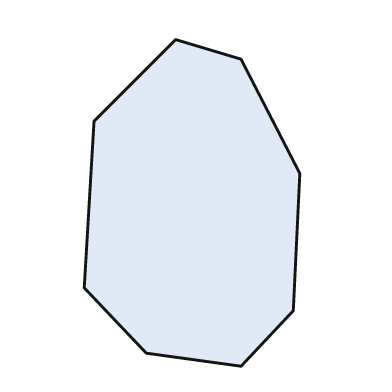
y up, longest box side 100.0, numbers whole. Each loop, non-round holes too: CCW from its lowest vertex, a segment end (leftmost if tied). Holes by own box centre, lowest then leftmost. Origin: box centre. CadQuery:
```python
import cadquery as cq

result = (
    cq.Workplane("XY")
    .moveTo(15.0, -50.0)
    .lineTo(31.0, -33.0)
    .lineTo(33.0, 9.0)
    .lineTo(15.0, 44.0)
    .lineTo(-5.0, 50.0)
    .lineTo(-30.0, 25.0)
    .lineTo(-33.0, -26.0)
    .lineTo(-14.0, -46.0)
    .close()
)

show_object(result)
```